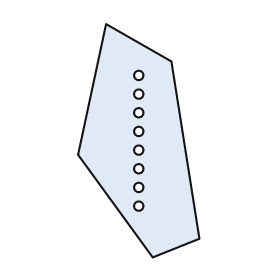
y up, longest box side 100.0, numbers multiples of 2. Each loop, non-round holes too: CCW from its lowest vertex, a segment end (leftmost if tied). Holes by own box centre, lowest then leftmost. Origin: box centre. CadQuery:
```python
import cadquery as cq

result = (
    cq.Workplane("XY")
    .moveTo(6.0, -50.0)
    .lineTo(26.0, -42.0)
    .lineTo(14.0, 34.0)
    .lineTo(-14.0, 50.0)
    .lineTo(-26.0, -6.0)
    .close()
    .moveTo(0.0, -28.0)
    .circle(2.0)
    .moveTo(0.0, -20.0)
    .circle(2.0)
    .moveTo(0.0, -12.0)
    .circle(2.0)
    .moveTo(0.0, -4.0)
    .circle(2.0)
    .moveTo(0.0, 4.0)
    .circle(2.0)
    .moveTo(0.0, 12.0)
    .circle(2.0)
    .moveTo(0.0, 20.0)
    .circle(2.0)
    .moveTo(0.0, 28.0)
    .circle(2.0)
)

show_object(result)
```